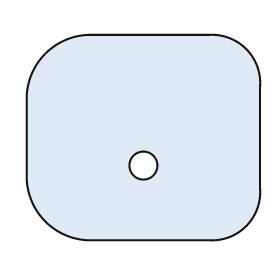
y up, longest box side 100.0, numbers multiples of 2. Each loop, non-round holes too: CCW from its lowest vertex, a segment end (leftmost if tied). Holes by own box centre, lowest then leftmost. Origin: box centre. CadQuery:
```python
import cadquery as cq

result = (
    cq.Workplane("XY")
    .moveTo(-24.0, -44.0)
    .lineTo(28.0, -44.0)
    .threePointArc((44.0, -38.0), (50.0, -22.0))
    .lineTo(50.0, 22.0)
    .threePointArc((44.0, 38.0), (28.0, 44.0))
    .lineTo(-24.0, 44.0)
    .threePointArc((-42.0, 36.0), (-50.0, 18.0))
    .lineTo(-50.0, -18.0)
    .threePointArc((-42.0, -36.0), (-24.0, -44.0))
    .close()
    .moveTo(0.0, -12.0)
    .circle(6.0)
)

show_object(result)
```